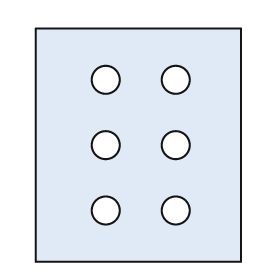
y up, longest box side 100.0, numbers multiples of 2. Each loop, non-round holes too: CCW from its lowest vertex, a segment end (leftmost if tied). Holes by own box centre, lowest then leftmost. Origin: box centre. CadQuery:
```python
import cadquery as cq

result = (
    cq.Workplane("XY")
    .moveTo(-44.0, -50.0)
    .lineTo(44.0, -50.0)
    .lineTo(44.0, 50.0)
    .lineTo(-44.0, 50.0)
    .close()
    .moveTo(-14.0, -28.0)
    .circle(6.0)
    .moveTo(16.0, -28.0)
    .circle(6.0)
    .moveTo(-14.0, 0.0)
    .circle(6.0)
    .moveTo(16.0, 0.0)
    .circle(6.0)
    .moveTo(-14.0, 28.0)
    .circle(6.0)
    .moveTo(16.0, 28.0)
    .circle(6.0)
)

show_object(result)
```